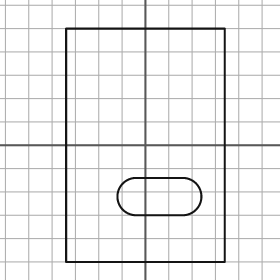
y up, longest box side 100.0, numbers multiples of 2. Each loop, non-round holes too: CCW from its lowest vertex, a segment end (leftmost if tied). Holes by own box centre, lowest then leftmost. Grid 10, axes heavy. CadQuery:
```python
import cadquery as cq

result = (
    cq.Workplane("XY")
    .moveTo(-34.0, -50.0)
    .lineTo(34.0, -50.0)
    .lineTo(34.0, 50.0)
    .lineTo(-34.0, 50.0)
    .close()
    .moveTo(-4.0, -30.0)
    .lineTo(16.0, -30.0)
    .threePointArc((24.0, -22.0), (16.0, -14.0))
    .lineTo(-4.0, -14.0)
    .threePointArc((-12.0, -22.0), (-4.0, -30.0))
    .close()
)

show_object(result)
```